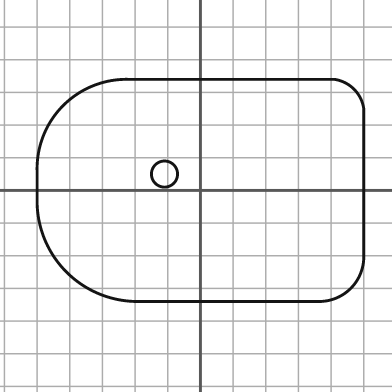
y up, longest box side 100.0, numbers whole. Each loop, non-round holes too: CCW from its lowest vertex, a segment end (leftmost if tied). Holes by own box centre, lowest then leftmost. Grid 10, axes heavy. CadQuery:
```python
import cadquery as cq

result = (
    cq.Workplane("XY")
    .moveTo(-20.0, -34.0)
    .lineTo(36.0, -34.0)
    .threePointArc((46.0, -30.0), (50.0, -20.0))
    .lineTo(50.0, 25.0)
    .threePointArc((47.0, 31.0), (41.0, 34.0))
    .lineTo(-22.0, 34.0)
    .threePointArc((-42.0, 26.0), (-50.0, 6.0))
    .lineTo(-50.0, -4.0)
    .threePointArc((-41.0, -25.0), (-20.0, -34.0))
    .close()
    .moveTo(-11.0, 5.0)
    .circle(4.0)
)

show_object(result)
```